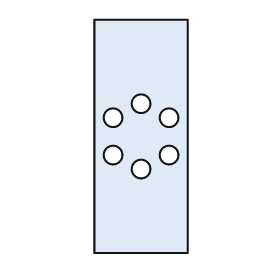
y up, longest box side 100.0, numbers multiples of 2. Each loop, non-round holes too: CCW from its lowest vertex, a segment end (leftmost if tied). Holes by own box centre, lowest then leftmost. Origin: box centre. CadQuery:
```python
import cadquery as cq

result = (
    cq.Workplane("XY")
    .moveTo(-20.0, -50.0)
    .lineTo(20.0, -50.0)
    .lineTo(20.0, 50.0)
    .lineTo(-20.0, 50.0)
    .close()
    .moveTo(0.0, -14.0)
    .circle(4.0)
    .moveTo(-12.0, -8.0)
    .circle(4.0)
    .moveTo(12.0, -8.0)
    .circle(4.0)
    .moveTo(-12.0, 8.0)
    .circle(4.0)
    .moveTo(12.0, 8.0)
    .circle(4.0)
    .moveTo(0.0, 14.0)
    .circle(4.0)
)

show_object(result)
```